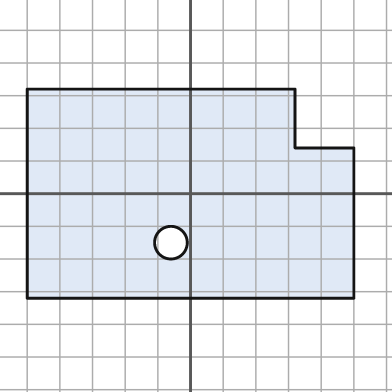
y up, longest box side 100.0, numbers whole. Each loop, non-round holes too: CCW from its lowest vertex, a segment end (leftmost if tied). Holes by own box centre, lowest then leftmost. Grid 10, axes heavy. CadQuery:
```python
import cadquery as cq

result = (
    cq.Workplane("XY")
    .moveTo(-50.0, -32.0)
    .lineTo(50.0, -32.0)
    .lineTo(50.0, 14.0)
    .lineTo(32.0, 14.0)
    .lineTo(32.0, 32.0)
    .lineTo(-50.0, 32.0)
    .close()
    .moveTo(-6.0, -15.0)
    .circle(5.0)
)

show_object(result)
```